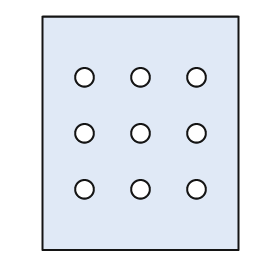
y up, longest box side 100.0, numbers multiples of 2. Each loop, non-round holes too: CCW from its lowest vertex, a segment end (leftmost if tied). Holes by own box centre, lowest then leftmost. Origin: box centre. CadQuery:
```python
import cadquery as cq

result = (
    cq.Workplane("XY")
    .moveTo(-42.0, -50.0)
    .lineTo(42.0, -50.0)
    .lineTo(42.0, 50.0)
    .lineTo(-42.0, 50.0)
    .close()
    .moveTo(-24.0, -24.0)
    .circle(4.0)
    .moveTo(0.0, -24.0)
    .circle(4.0)
    .moveTo(24.0, -24.0)
    .circle(4.0)
    .moveTo(-24.0, 0.0)
    .circle(4.0)
    .moveTo(0.0, 0.0)
    .circle(4.0)
    .moveTo(24.0, 0.0)
    .circle(4.0)
    .moveTo(-24.0, 24.0)
    .circle(4.0)
    .moveTo(0.0, 24.0)
    .circle(4.0)
    .moveTo(24.0, 24.0)
    .circle(4.0)
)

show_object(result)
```